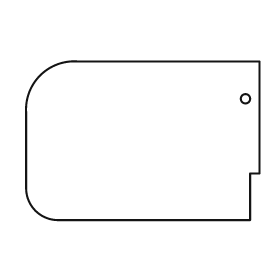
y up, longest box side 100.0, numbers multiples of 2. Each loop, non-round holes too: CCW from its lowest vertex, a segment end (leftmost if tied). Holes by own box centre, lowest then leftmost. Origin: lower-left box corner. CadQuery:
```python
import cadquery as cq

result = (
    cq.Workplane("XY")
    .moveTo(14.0, 0.0)
    .lineTo(96.0, 0.0)
    .lineTo(96.0, 20.0)
    .lineTo(100.0, 20.0)
    .lineTo(100.0, 68.0)
    .lineTo(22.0, 68.0)
    .threePointArc((6.0, 62.0), (0.0, 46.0))
    .lineTo(0.0, 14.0)
    .threePointArc((4.0, 4.0), (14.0, 0.0))
    .close()
    .moveTo(94.0, 52.0)
    .circle(2.0)
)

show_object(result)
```